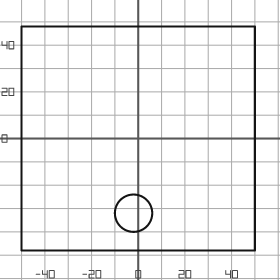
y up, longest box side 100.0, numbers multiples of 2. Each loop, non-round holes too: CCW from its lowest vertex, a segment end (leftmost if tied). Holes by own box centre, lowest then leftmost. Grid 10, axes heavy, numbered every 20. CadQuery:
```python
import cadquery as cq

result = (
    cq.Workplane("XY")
    .moveTo(-50.0, -48.0)
    .lineTo(50.0, -48.0)
    .lineTo(50.0, 48.0)
    .lineTo(-50.0, 48.0)
    .close()
    .moveTo(-2.0, -32.0)
    .circle(8.0)
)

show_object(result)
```